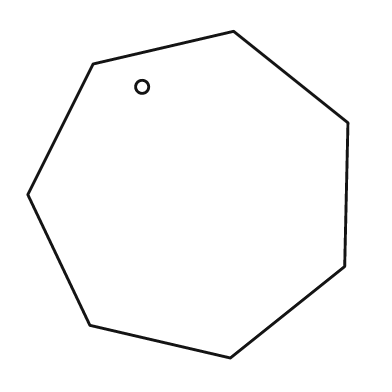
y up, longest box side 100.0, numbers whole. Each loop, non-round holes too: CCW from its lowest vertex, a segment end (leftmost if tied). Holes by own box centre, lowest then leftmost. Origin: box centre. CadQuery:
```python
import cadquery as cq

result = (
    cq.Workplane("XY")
    .moveTo(13.0, -50.0)
    .lineTo(48.0, -22.0)
    .lineTo(49.0, 22.0)
    .lineTo(14.0, 50.0)
    .lineTo(-29.0, 40.0)
    .lineTo(-49.0, 0.0)
    .lineTo(-30.0, -40.0)
    .close()
    .moveTo(-14.0, 33.0)
    .circle(2.0)
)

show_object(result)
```